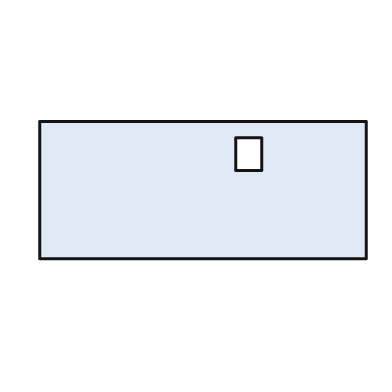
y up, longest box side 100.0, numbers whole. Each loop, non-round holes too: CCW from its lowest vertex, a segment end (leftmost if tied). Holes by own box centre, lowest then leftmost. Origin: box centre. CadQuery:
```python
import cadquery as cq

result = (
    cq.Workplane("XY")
    .moveTo(-50.0, -21.0)
    .lineTo(50.0, -21.0)
    .lineTo(50.0, 21.0)
    .lineTo(-50.0, 21.0)
    .close()
    .moveTo(10.0, 6.0)
    .lineTo(18.0, 6.0)
    .lineTo(18.0, 16.0)
    .lineTo(10.0, 16.0)
    .close()
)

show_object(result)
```